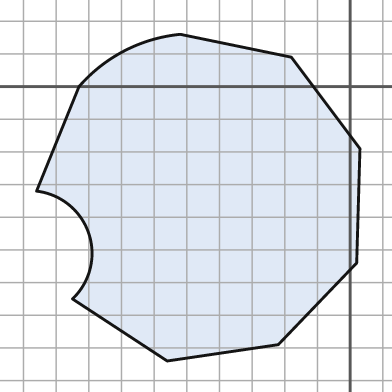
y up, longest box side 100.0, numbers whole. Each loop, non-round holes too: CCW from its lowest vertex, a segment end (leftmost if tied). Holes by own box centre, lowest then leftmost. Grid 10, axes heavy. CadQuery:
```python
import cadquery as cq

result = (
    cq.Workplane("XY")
    .moveTo(-56.0, -84.0)
    .lineTo(-22.0, -79.0)
    .lineTo(2.0, -54.0)
    .lineTo(3.0, -19.0)
    .lineTo(-18.0, 9.0)
    .lineTo(-52.0, 16.0)
    .threePointArc((-69.0, 11.0), (-83.0, 0.0))
    .lineTo(-96.0, -32.0)
    .threePointArc((-80.0, -45.0), (-85.0, -65.0))
    .close()
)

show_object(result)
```